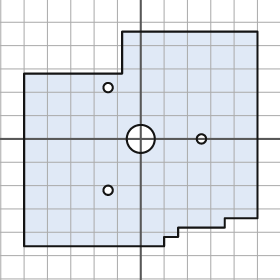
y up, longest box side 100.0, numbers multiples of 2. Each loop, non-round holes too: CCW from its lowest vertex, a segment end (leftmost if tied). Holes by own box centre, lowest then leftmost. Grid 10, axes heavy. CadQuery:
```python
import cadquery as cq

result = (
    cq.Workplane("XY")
    .moveTo(-50.0, -46.0)
    .lineTo(10.0, -46.0)
    .lineTo(10.0, -42.0)
    .lineTo(16.0, -42.0)
    .lineTo(16.0, -38.0)
    .lineTo(36.0, -38.0)
    .lineTo(36.0, -34.0)
    .lineTo(50.0, -34.0)
    .lineTo(50.0, 46.0)
    .lineTo(-8.0, 46.0)
    .lineTo(-8.0, 28.0)
    .lineTo(-50.0, 28.0)
    .close()
    .moveTo(-14.0, -22.0)
    .circle(2.0)
    .moveTo(0.0, 0.0)
    .circle(6.0)
    .moveTo(26.0, 0.0)
    .circle(2.0)
    .moveTo(-14.0, 22.0)
    .circle(2.0)
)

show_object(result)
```